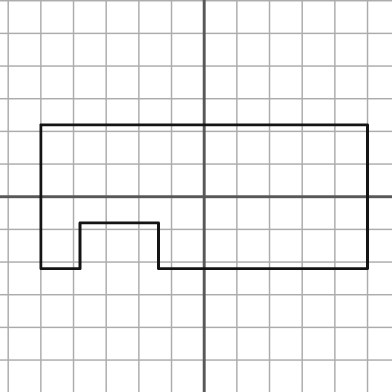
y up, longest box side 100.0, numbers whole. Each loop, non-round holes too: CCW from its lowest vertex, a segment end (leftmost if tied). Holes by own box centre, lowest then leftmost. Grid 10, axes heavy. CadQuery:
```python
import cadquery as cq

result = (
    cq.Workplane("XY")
    .moveTo(-50.0, -22.0)
    .lineTo(-38.0, -22.0)
    .lineTo(-38.0, -8.0)
    .lineTo(-14.0, -8.0)
    .lineTo(-14.0, -22.0)
    .lineTo(50.0, -22.0)
    .lineTo(50.0, 22.0)
    .lineTo(-50.0, 22.0)
    .close()
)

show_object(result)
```